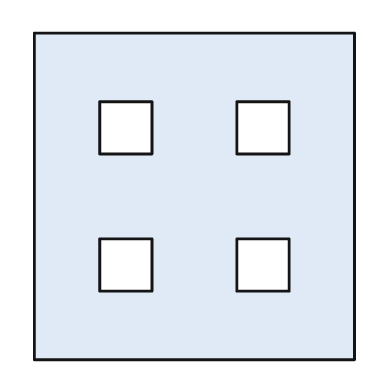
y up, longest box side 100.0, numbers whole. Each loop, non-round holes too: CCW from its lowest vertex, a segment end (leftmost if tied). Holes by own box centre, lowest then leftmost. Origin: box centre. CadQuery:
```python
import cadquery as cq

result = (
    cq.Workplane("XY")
    .moveTo(-49.0, -50.0)
    .lineTo(49.0, -50.0)
    .lineTo(49.0, 50.0)
    .lineTo(-49.0, 50.0)
    .close()
    .moveTo(-29.0, -29.0)
    .lineTo(-13.0, -29.0)
    .lineTo(-13.0, -13.0)
    .lineTo(-29.0, -13.0)
    .close()
    .moveTo(13.0, -29.0)
    .lineTo(29.0, -29.0)
    .lineTo(29.0, -13.0)
    .lineTo(13.0, -13.0)
    .close()
    .moveTo(-29.0, 13.0)
    .lineTo(-13.0, 13.0)
    .lineTo(-13.0, 29.0)
    .lineTo(-29.0, 29.0)
    .close()
    .moveTo(13.0, 13.0)
    .lineTo(29.0, 13.0)
    .lineTo(29.0, 29.0)
    .lineTo(13.0, 29.0)
    .close()
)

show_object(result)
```